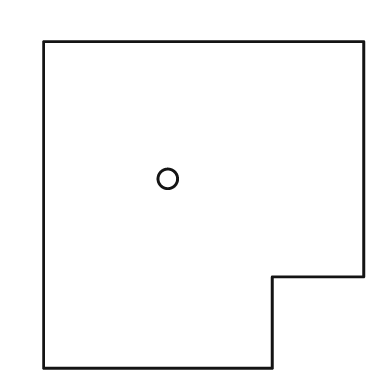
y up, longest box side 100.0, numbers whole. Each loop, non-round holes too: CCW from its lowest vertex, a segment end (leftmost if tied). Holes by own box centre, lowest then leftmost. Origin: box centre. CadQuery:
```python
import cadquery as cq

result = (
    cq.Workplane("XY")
    .moveTo(-49.0, -50.0)
    .lineTo(21.0, -50.0)
    .lineTo(21.0, -22.0)
    .lineTo(49.0, -22.0)
    .lineTo(49.0, 50.0)
    .lineTo(-49.0, 50.0)
    .close()
    .moveTo(-11.0, 8.0)
    .circle(3.0)
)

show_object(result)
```